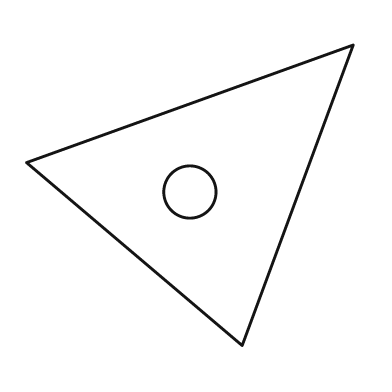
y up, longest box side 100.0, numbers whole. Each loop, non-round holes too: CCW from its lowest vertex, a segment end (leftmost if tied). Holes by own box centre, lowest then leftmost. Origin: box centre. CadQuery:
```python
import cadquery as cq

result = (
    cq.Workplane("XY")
    .moveTo(16.0, -46.0)
    .lineTo(50.0, 46.0)
    .lineTo(-50.0, 10.0)
    .close()
    .moveTo(0.0, 1.0)
    .circle(8.0)
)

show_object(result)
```